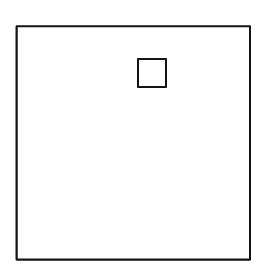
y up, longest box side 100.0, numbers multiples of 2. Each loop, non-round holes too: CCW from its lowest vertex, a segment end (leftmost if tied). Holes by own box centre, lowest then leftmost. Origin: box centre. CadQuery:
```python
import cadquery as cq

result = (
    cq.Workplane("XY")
    .moveTo(-50.0, -50.0)
    .lineTo(50.0, -50.0)
    .lineTo(50.0, 50.0)
    .lineTo(-50.0, 50.0)
    .close()
    .moveTo(2.0, 24.0)
    .lineTo(14.0, 24.0)
    .lineTo(14.0, 36.0)
    .lineTo(2.0, 36.0)
    .close()
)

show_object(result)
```